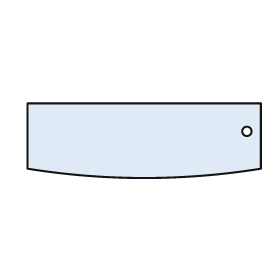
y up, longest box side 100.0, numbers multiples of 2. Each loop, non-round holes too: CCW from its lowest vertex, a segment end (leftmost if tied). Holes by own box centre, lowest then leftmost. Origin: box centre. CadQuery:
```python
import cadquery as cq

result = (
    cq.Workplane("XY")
    .moveTo(-50.0, -12.0)
    .threePointArc((0.0, -16.0), (50.0, -12.0))
    .lineTo(50.0, 16.0)
    .lineTo(-50.0, 16.0)
    .close()
    .moveTo(44.0, 4.0)
    .circle(2.0)
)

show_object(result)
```